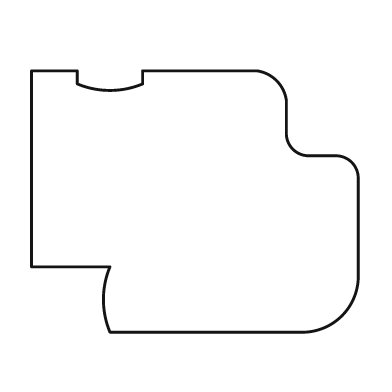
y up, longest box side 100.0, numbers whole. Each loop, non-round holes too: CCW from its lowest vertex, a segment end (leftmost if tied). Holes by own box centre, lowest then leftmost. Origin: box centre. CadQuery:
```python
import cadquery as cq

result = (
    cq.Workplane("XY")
    .moveTo(-26.0, -40.0)
    .lineTo(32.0, -40.0)
    .threePointArc((45.0, -35.0), (50.0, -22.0))
    .lineTo(50.0, 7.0)
    .threePointArc((48.0, 12.0), (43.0, 14.0))
    .lineTo(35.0, 14.0)
    .threePointArc((30.0, 16.0), (28.0, 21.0))
    .lineTo(28.0, 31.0)
    .threePointArc((25.0, 37.0), (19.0, 40.0))
    .lineTo(-16.0, 40.0)
    .lineTo(-16.0, 36.0)
    .threePointArc((-26.0, 34.0), (-36.0, 36.0))
    .lineTo(-36.0, 40.0)
    .lineTo(-50.0, 40.0)
    .lineTo(-50.0, -20.0)
    .lineTo(-26.0, -20.0)
    .threePointArc((-28.0, -30.0), (-26.0, -40.0))
    .close()
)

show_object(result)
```